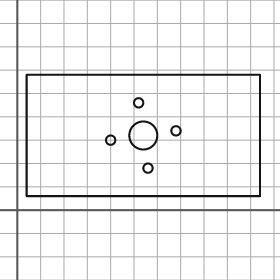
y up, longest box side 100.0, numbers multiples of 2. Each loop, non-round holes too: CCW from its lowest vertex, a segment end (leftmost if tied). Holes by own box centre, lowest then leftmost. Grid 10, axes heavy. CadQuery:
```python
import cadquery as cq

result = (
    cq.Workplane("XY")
    .moveTo(4.0, 6.0)
    .lineTo(104.0, 6.0)
    .lineTo(104.0, 58.0)
    .lineTo(4.0, 58.0)
    .close()
    .moveTo(56.0, 18.0)
    .circle(2.0)
    .moveTo(40.0, 30.0)
    .circle(2.0)
    .moveTo(54.0, 32.0)
    .circle(6.0)
    .moveTo(68.0, 34.0)
    .circle(2.0)
    .moveTo(52.0, 46.0)
    .circle(2.0)
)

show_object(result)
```